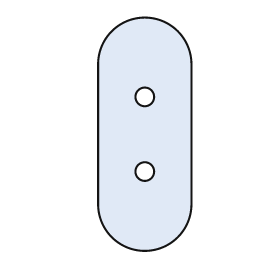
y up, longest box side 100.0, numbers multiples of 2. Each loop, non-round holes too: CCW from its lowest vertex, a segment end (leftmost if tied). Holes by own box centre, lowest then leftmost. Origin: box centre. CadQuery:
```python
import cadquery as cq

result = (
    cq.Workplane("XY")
    .moveTo(-20.0, -30.0)
    .threePointArc((0.0, -50.0), (20.0, -30.0))
    .lineTo(20.0, 30.0)
    .threePointArc((0.0, 50.0), (-20.0, 30.0))
    .close()
    .moveTo(0.0, -16.0)
    .circle(4.0)
    .moveTo(0.0, 16.0)
    .circle(4.0)
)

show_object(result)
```